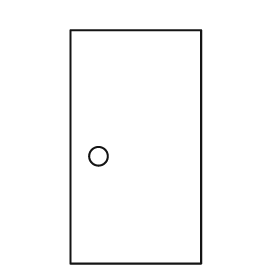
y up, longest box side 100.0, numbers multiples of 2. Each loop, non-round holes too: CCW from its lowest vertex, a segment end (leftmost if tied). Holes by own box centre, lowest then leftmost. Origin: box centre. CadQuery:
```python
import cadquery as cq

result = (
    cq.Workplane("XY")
    .moveTo(-28.0, -50.0)
    .lineTo(28.0, -50.0)
    .lineTo(28.0, 50.0)
    .lineTo(-28.0, 50.0)
    .close()
    .moveTo(-16.0, -4.0)
    .circle(4.0)
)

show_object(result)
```